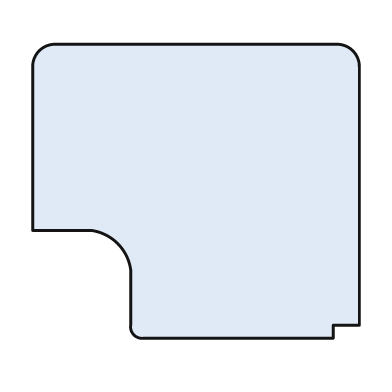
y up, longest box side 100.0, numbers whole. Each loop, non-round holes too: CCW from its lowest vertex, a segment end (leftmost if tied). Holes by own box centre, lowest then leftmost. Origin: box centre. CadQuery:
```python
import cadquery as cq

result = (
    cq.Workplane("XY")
    .moveTo(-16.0, -45.0)
    .lineTo(42.0, -45.0)
    .lineTo(42.0, -41.0)
    .lineTo(50.0, -41.0)
    .lineTo(50.0, 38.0)
    .threePointArc((48.0, 43.0), (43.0, 45.0))
    .lineTo(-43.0, 45.0)
    .threePointArc((-48.0, 43.0), (-50.0, 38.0))
    .lineTo(-50.0, -12.0)
    .lineTo(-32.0, -12.0)
    .threePointArc((-24.0, -16.0), (-20.0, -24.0))
    .lineTo(-20.0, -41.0)
    .threePointArc((-19.0, -44.0), (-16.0, -45.0))
    .close()
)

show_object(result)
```